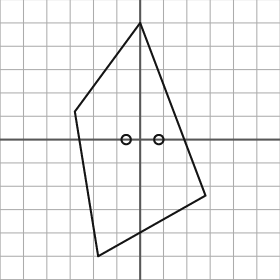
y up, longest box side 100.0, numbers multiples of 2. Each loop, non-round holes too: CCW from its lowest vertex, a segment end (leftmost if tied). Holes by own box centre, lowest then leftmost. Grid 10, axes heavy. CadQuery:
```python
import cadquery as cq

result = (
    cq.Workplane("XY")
    .moveTo(-18.0, -50.0)
    .lineTo(28.0, -24.0)
    .lineTo(0.0, 50.0)
    .lineTo(-28.0, 12.0)
    .close()
    .moveTo(-6.0, 0.0)
    .circle(2.0)
    .moveTo(8.0, 0.0)
    .circle(2.0)
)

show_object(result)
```